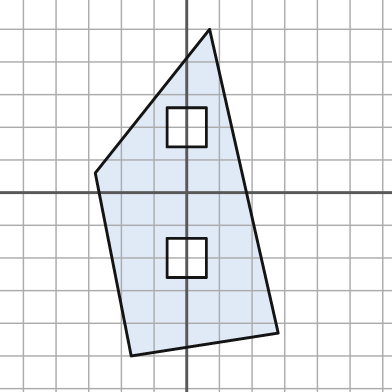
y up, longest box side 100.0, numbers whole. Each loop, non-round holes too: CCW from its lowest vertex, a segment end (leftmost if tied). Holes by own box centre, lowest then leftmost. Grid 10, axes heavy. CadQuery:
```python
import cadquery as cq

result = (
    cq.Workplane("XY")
    .moveTo(-17.0, -50.0)
    .lineTo(28.0, -43.0)
    .lineTo(7.0, 50.0)
    .lineTo(-28.0, 6.0)
    .close()
    .moveTo(-6.0, -26.0)
    .lineTo(6.0, -26.0)
    .lineTo(6.0, -14.0)
    .lineTo(-6.0, -14.0)
    .close()
    .moveTo(-6.0, 14.0)
    .lineTo(6.0, 14.0)
    .lineTo(6.0, 26.0)
    .lineTo(-6.0, 26.0)
    .close()
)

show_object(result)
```